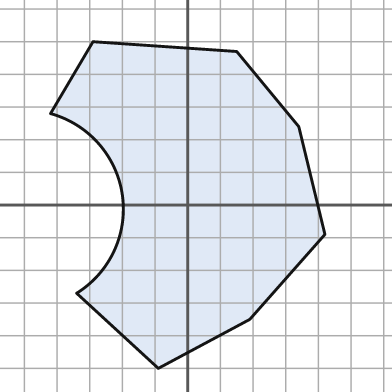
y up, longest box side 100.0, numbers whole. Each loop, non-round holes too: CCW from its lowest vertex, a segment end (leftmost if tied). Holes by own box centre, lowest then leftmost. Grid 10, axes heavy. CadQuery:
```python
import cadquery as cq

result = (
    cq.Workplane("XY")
    .moveTo(-9.0, -50.0)
    .lineTo(19.0, -35.0)
    .lineTo(42.0, -9.0)
    .lineTo(34.0, 24.0)
    .lineTo(15.0, 47.0)
    .lineTo(-29.0, 50.0)
    .lineTo(-42.0, 28.0)
    .threePointArc((-20.0, 3.0), (-34.0, -27.0))
    .close()
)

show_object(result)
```